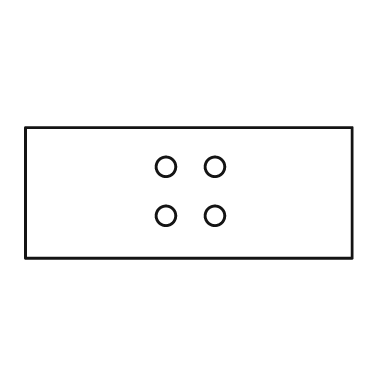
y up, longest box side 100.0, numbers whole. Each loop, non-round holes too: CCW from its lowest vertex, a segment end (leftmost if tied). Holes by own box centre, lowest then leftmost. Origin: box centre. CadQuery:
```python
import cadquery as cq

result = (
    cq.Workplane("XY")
    .moveTo(-50.0, -20.0)
    .lineTo(50.0, -20.0)
    .lineTo(50.0, 20.0)
    .lineTo(-50.0, 20.0)
    .close()
    .moveTo(-7.0, -7.0)
    .circle(3.0)
    .moveTo(8.0, -7.0)
    .circle(3.0)
    .moveTo(-7.0, 8.0)
    .circle(3.0)
    .moveTo(8.0, 8.0)
    .circle(3.0)
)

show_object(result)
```